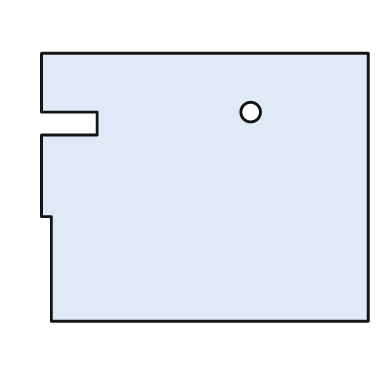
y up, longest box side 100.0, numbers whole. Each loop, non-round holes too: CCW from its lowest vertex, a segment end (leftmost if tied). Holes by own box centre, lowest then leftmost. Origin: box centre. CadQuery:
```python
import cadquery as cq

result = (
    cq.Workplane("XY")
    .moveTo(-47.0, -41.0)
    .lineTo(50.0, -41.0)
    .lineTo(50.0, 41.0)
    .lineTo(-50.0, 41.0)
    .lineTo(-50.0, 23.0)
    .lineTo(-33.0, 23.0)
    .lineTo(-33.0, 16.0)
    .lineTo(-50.0, 16.0)
    .lineTo(-50.0, -9.0)
    .lineTo(-47.0, -9.0)
    .close()
    .moveTo(14.0, 23.0)
    .circle(3.0)
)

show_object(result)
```